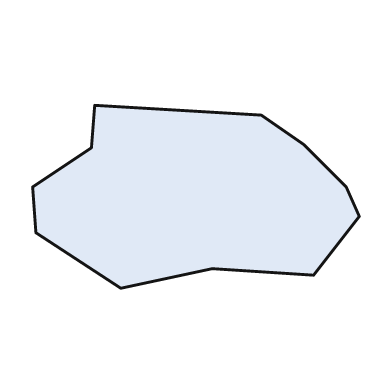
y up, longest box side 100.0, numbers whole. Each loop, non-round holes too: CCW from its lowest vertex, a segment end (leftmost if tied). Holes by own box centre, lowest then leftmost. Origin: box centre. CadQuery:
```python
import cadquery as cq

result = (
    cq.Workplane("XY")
    .moveTo(-23.0, -28.0)
    .lineTo(5.0, -22.0)
    .lineTo(36.0, -24.0)
    .lineTo(50.0, -6.0)
    .lineTo(46.0, 3.0)
    .lineTo(33.0, 16.0)
    .lineTo(20.0, 25.0)
    .lineTo(-31.0, 28.0)
    .lineTo(-32.0, 15.0)
    .lineTo(-50.0, 3.0)
    .lineTo(-49.0, -11.0)
    .close()
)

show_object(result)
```